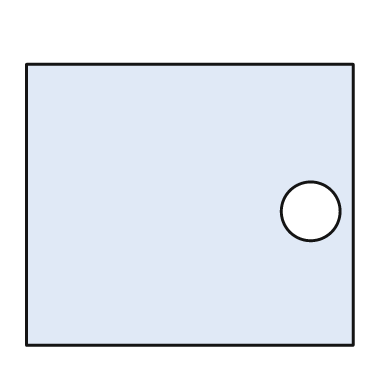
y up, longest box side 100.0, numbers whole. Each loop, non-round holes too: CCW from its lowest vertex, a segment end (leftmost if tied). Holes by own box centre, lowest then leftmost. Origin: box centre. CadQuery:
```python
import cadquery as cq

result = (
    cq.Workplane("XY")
    .moveTo(-50.0, -43.0)
    .lineTo(50.0, -43.0)
    .lineTo(50.0, 43.0)
    .lineTo(-50.0, 43.0)
    .close()
    .moveTo(37.0, -2.0)
    .circle(9.0)
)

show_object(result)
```